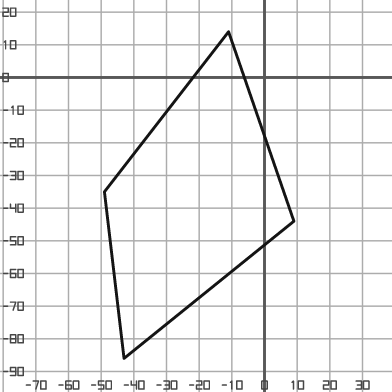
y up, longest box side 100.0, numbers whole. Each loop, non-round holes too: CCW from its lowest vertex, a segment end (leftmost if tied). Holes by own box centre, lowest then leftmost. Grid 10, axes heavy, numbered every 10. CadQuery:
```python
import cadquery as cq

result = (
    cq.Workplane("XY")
    .moveTo(-43.0, -86.0)
    .lineTo(9.0, -44.0)
    .lineTo(-11.0, 14.0)
    .lineTo(-49.0, -35.0)
    .close()
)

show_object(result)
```